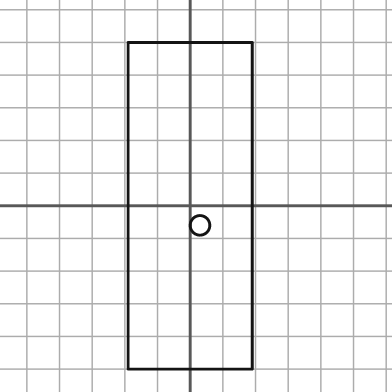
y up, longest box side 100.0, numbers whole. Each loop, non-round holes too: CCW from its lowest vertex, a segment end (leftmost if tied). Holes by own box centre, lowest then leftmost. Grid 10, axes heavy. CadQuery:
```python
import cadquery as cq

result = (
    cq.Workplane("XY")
    .moveTo(-19.0, -50.0)
    .lineTo(19.0, -50.0)
    .lineTo(19.0, 50.0)
    .lineTo(-19.0, 50.0)
    .close()
    .moveTo(3.0, -6.0)
    .circle(3.0)
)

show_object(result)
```